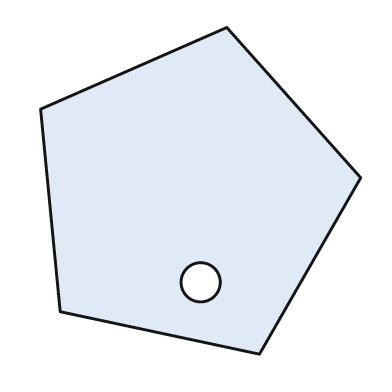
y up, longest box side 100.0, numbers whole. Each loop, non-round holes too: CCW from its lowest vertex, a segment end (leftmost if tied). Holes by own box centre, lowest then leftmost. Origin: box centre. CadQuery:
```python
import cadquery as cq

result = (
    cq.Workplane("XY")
    .moveTo(18.0, -50.0)
    .lineTo(49.0, 4.0)
    .lineTo(8.0, 50.0)
    .lineTo(-49.0, 25.0)
    .lineTo(-43.0, -37.0)
    .close()
    .moveTo(0.0, -28.0)
    .circle(6.0)
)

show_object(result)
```